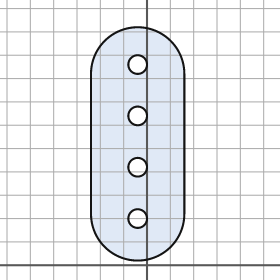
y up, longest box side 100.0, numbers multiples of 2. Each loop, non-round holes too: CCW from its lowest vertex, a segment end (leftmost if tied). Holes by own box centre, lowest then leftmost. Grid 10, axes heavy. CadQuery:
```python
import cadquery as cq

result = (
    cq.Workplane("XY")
    .moveTo(-24.0, 22.0)
    .threePointArc((-4.0, 2.0), (16.0, 22.0))
    .lineTo(16.0, 82.0)
    .threePointArc((-4.0, 102.0), (-24.0, 82.0))
    .close()
    .moveTo(-4.0, 20.0)
    .circle(4.0)
    .moveTo(-4.0, 42.0)
    .circle(4.0)
    .moveTo(-4.0, 64.0)
    .circle(4.0)
    .moveTo(-4.0, 86.0)
    .circle(4.0)
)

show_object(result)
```